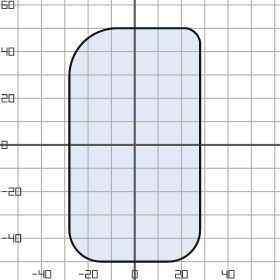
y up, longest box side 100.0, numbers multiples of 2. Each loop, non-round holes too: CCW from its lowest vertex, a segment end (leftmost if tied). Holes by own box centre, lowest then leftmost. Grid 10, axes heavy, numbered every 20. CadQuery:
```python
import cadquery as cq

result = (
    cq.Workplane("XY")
    .moveTo(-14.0, -50.0)
    .lineTo(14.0, -50.0)
    .threePointArc((24.0, -46.0), (28.0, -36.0))
    .lineTo(28.0, 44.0)
    .threePointArc((26.0, 48.0), (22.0, 50.0))
    .lineTo(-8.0, 50.0)
    .threePointArc((-22.0, 44.0), (-28.0, 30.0))
    .lineTo(-28.0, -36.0)
    .threePointArc((-24.0, -46.0), (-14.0, -50.0))
    .close()
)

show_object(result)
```